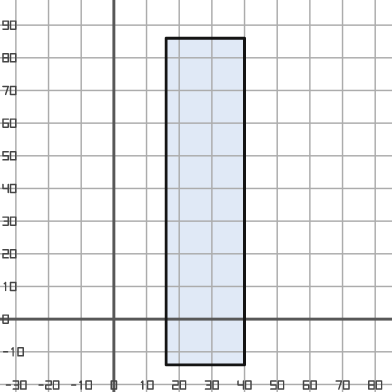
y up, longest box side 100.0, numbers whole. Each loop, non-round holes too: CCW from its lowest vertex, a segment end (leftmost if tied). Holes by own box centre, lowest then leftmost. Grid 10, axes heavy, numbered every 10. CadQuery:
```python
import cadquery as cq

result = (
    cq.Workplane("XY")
    .moveTo(16.0, -14.0)
    .lineTo(40.0, -14.0)
    .lineTo(40.0, 86.0)
    .lineTo(16.0, 86.0)
    .close()
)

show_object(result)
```